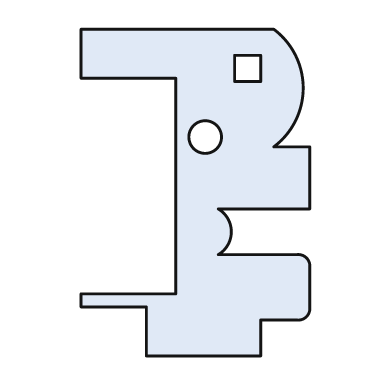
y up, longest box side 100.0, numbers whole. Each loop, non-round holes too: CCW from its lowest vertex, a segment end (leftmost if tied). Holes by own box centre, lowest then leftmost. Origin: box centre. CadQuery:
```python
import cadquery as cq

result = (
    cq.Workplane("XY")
    .moveTo(-15.0, -50.0)
    .lineTo(20.0, -50.0)
    .lineTo(20.0, -39.0)
    .lineTo(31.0, -39.0)
    .threePointArc((34.0, -38.0), (35.0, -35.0))
    .lineTo(35.0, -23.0)
    .threePointArc((34.0, -20.0), (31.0, -19.0))
    .lineTo(7.0, -19.0)
    .threePointArc((11.0, -12.0), (7.0, -5.0))
    .lineTo(35.0, -5.0)
    .lineTo(35.0, 14.0)
    .lineTo(24.0, 14.0)
    .threePointArc((33.0, 32.0), (24.0, 50.0))
    .lineTo(-35.0, 50.0)
    .lineTo(-35.0, 35.0)
    .lineTo(-6.0, 35.0)
    .lineTo(-6.0, -31.0)
    .lineTo(-35.0, -31.0)
    .lineTo(-35.0, -35.0)
    .lineTo(-15.0, -35.0)
    .close()
    .moveTo(3.0, 17.0)
    .circle(5.0)
    .moveTo(12.0, 34.0)
    .lineTo(20.0, 34.0)
    .lineTo(20.0, 42.0)
    .lineTo(12.0, 42.0)
    .close()
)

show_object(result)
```